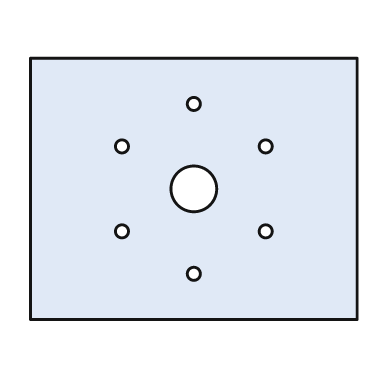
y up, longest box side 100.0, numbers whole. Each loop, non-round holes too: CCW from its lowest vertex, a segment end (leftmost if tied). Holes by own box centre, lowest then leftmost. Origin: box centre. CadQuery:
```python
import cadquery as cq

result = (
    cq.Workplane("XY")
    .moveTo(-50.0, -40.0)
    .lineTo(50.0, -40.0)
    .lineTo(50.0, 40.0)
    .lineTo(-50.0, 40.0)
    .close()
    .moveTo(0.0, -26.0)
    .circle(2.0)
    .moveTo(-22.0, -13.0)
    .circle(2.0)
    .moveTo(22.0, -13.0)
    .circle(2.0)
    .moveTo(0.0, 0.0)
    .circle(7.0)
    .moveTo(-22.0, 13.0)
    .circle(2.0)
    .moveTo(22.0, 13.0)
    .circle(2.0)
    .moveTo(0.0, 26.0)
    .circle(2.0)
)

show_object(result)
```